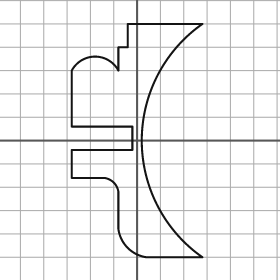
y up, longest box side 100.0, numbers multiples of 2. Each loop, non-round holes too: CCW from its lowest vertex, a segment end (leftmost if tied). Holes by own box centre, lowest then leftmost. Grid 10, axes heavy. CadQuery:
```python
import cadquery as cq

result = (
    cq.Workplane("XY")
    .moveTo(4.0, -50.0)
    .lineTo(28.0, -50.0)
    .threePointArc((2.0, 0.0), (28.0, 50.0))
    .lineTo(-4.0, 50.0)
    .lineTo(-4.0, 40.0)
    .lineTo(-8.0, 40.0)
    .lineTo(-8.0, 30.0)
    .threePointArc((-18.0, 36.0), (-28.0, 30.0))
    .lineTo(-28.0, 6.0)
    .lineTo(-2.0, 6.0)
    .lineTo(-2.0, -4.0)
    .lineTo(-28.0, -4.0)
    .lineTo(-28.0, -16.0)
    .lineTo(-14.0, -16.0)
    .threePointArc((-10.0, -18.0), (-8.0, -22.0))
    .lineTo(-8.0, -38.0)
    .threePointArc((-4.0, -46.0), (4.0, -50.0))
    .close()
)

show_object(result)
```